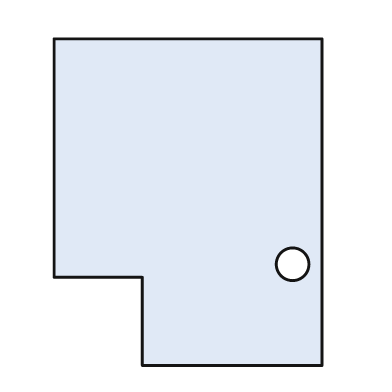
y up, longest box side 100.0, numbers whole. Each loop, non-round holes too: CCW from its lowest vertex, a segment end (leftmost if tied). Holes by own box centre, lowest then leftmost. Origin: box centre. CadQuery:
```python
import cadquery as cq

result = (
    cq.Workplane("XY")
    .moveTo(-14.0, -50.0)
    .lineTo(41.0, -50.0)
    .lineTo(41.0, 50.0)
    .lineTo(-41.0, 50.0)
    .lineTo(-41.0, -23.0)
    .lineTo(-14.0, -23.0)
    .close()
    .moveTo(32.0, -19.0)
    .circle(5.0)
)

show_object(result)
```